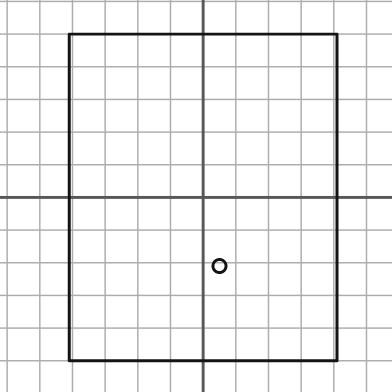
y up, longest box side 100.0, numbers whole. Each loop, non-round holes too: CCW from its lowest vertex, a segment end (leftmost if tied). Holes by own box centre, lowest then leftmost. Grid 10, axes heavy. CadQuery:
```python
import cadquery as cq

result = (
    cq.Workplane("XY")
    .moveTo(-41.0, -50.0)
    .lineTo(41.0, -50.0)
    .lineTo(41.0, 50.0)
    .lineTo(-41.0, 50.0)
    .close()
    .moveTo(5.0, -21.0)
    .circle(2.0)
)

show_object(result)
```